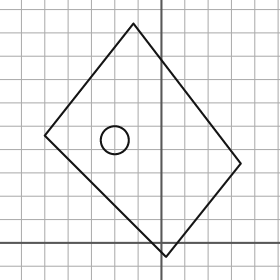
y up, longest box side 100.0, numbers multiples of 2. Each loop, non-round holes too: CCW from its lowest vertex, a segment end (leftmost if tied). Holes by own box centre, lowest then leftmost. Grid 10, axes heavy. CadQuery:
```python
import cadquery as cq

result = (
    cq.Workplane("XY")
    .moveTo(2.0, -6.0)
    .lineTo(34.0, 34.0)
    .lineTo(-12.0, 94.0)
    .lineTo(-50.0, 46.0)
    .close()
    .moveTo(-20.0, 44.0)
    .circle(6.0)
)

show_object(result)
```